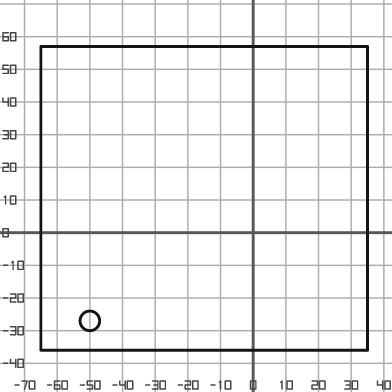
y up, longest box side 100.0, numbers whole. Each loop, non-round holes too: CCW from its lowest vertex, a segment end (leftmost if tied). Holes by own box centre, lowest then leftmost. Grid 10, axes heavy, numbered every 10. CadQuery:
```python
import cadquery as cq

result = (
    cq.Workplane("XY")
    .moveTo(-65.0, -36.0)
    .lineTo(35.0, -36.0)
    .lineTo(35.0, 57.0)
    .lineTo(-65.0, 57.0)
    .close()
    .moveTo(-50.0, -27.0)
    .circle(3.0)
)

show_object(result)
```